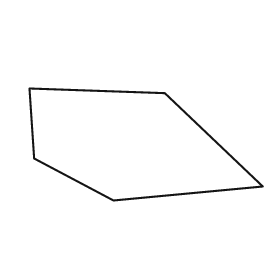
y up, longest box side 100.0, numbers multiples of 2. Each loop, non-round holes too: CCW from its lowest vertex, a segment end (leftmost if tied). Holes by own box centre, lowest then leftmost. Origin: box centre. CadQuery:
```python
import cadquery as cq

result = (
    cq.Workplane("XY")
    .moveTo(-14.0, -24.0)
    .lineTo(50.0, -18.0)
    .lineTo(8.0, 22.0)
    .lineTo(-50.0, 24.0)
    .lineTo(-48.0, -6.0)
    .close()
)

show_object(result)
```